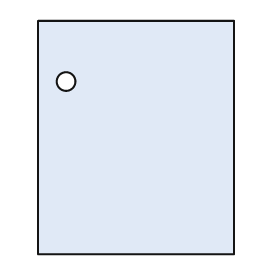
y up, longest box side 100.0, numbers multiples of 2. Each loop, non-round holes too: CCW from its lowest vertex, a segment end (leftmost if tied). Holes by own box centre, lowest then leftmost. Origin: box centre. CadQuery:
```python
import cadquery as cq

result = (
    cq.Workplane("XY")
    .moveTo(-42.0, -50.0)
    .lineTo(42.0, -50.0)
    .lineTo(42.0, 50.0)
    .lineTo(-42.0, 50.0)
    .close()
    .moveTo(-30.0, 24.0)
    .circle(4.0)
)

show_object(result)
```